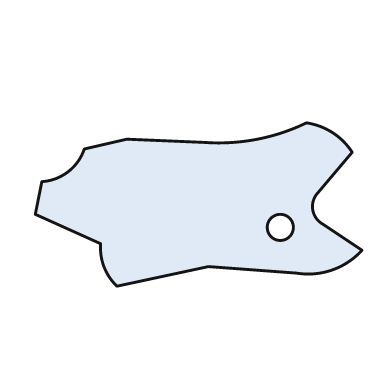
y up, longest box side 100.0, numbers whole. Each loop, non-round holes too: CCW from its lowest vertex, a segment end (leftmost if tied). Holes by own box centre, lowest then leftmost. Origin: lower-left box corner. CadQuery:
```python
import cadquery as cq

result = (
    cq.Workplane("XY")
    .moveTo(25.0, 0.0)
    .lineTo(53.0, 6.0)
    .lineTo(80.0, 4.0)
    .threePointArc((91.0, 5.0), (100.0, 11.0))
    .lineTo(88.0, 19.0)
    .threePointArc((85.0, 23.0), (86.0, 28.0))
    .lineTo(97.0, 41.0)
    .threePointArc((91.0, 47.0), (83.0, 50.0))
    .threePointArc((68.0, 45.0), (52.0, 44.0))
    .lineTo(28.0, 45.0)
    .lineTo(15.0, 42.0)
    .threePointArc((10.0, 35.0), (2.0, 32.0))
    .lineTo(0.0, 22.0)
    .lineTo(20.0, 13.0)
    .threePointArc((21.0, 6.0), (25.0, 0.0))
    .close()
    .moveTo(75.0, 18.0)
    .circle(4.0)
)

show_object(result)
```